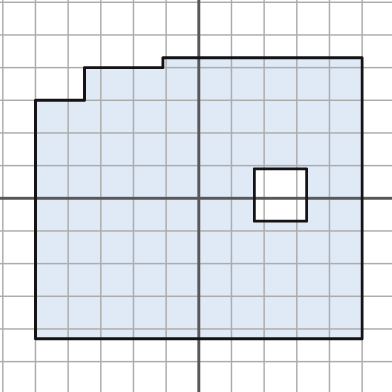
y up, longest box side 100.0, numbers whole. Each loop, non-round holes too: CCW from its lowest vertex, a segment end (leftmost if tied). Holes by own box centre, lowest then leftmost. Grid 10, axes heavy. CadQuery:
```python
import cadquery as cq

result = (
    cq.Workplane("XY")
    .moveTo(-50.0, -43.0)
    .lineTo(50.0, -43.0)
    .lineTo(50.0, 43.0)
    .lineTo(-11.0, 43.0)
    .lineTo(-11.0, 40.0)
    .lineTo(-35.0, 40.0)
    .lineTo(-35.0, 30.0)
    .lineTo(-50.0, 30.0)
    .close()
    .moveTo(17.0, -7.0)
    .lineTo(33.0, -7.0)
    .lineTo(33.0, 9.0)
    .lineTo(17.0, 9.0)
    .close()
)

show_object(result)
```